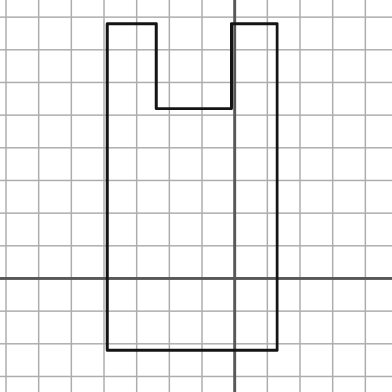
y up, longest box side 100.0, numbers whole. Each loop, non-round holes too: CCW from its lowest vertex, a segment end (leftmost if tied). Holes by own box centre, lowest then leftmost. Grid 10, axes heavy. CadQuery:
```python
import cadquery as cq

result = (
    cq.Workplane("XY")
    .moveTo(-39.0, -22.0)
    .lineTo(13.0, -22.0)
    .lineTo(13.0, 78.0)
    .lineTo(-1.0, 78.0)
    .lineTo(-1.0, 52.0)
    .lineTo(-24.0, 52.0)
    .lineTo(-24.0, 78.0)
    .lineTo(-39.0, 78.0)
    .close()
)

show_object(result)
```